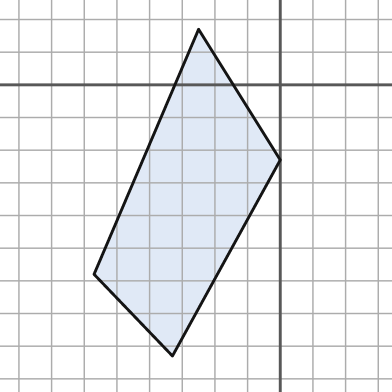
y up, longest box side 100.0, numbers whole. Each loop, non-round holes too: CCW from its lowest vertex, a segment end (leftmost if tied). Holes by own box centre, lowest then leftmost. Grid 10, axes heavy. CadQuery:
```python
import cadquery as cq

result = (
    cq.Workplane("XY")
    .moveTo(-33.0, -83.0)
    .lineTo(0.0, -23.0)
    .lineTo(-25.0, 17.0)
    .lineTo(-57.0, -58.0)
    .close()
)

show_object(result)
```